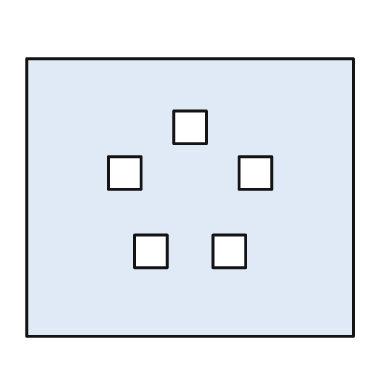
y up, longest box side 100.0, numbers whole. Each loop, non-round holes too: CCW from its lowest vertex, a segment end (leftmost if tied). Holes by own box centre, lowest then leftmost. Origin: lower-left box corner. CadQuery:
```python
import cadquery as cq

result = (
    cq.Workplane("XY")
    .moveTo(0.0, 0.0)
    .lineTo(100.0, 0.0)
    .lineTo(100.0, 85.0)
    .lineTo(0.0, 85.0)
    .close()
    .moveTo(33.0, 21.0)
    .lineTo(43.0, 21.0)
    .lineTo(43.0, 31.0)
    .lineTo(33.0, 31.0)
    .close()
    .moveTo(57.0, 21.0)
    .lineTo(67.0, 21.0)
    .lineTo(67.0, 31.0)
    .lineTo(57.0, 31.0)
    .close()
    .moveTo(25.0, 45.0)
    .lineTo(35.0, 45.0)
    .lineTo(35.0, 55.0)
    .lineTo(25.0, 55.0)
    .close()
    .moveTo(65.0, 45.0)
    .lineTo(75.0, 45.0)
    .lineTo(75.0, 55.0)
    .lineTo(65.0, 55.0)
    .close()
    .moveTo(45.0, 59.0)
    .lineTo(55.0, 59.0)
    .lineTo(55.0, 69.0)
    .lineTo(45.0, 69.0)
    .close()
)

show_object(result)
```